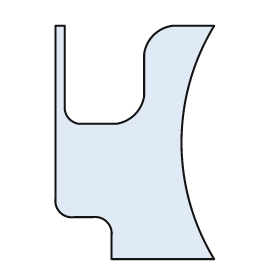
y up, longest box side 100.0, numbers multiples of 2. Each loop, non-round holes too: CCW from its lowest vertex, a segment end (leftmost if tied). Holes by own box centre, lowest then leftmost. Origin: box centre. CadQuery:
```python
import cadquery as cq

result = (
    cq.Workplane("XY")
    .moveTo(-10.0, -50.0)
    .lineTo(34.0, -50.0)
    .threePointArc((20.0, 0.0), (34.0, 50.0))
    .lineTo(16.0, 50.0)
    .threePointArc((8.0, 46.0), (4.0, 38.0))
    .lineTo(4.0, 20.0)
    .threePointArc((0.0, 12.0), (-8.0, 8.0))
    .lineTo(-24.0, 8.0)
    .threePointArc((-28.0, 10.0), (-30.0, 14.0))
    .lineTo(-30.0, 50.0)
    .lineTo(-34.0, 50.0)
    .lineTo(-34.0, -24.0)
    .threePointArc((-32.0, -30.0), (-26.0, -32.0))
    .lineTo(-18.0, -32.0)
    .threePointArc((-12.0, -34.0), (-10.0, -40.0))
    .close()
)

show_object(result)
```